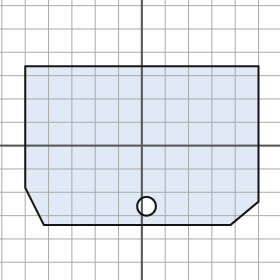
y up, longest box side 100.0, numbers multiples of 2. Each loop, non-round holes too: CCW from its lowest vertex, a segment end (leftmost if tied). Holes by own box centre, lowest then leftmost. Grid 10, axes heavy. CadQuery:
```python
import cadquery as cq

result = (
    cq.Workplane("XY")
    .moveTo(-42.0, -34.0)
    .lineTo(38.0, -34.0)
    .lineTo(50.0, -24.0)
    .lineTo(50.0, 34.0)
    .lineTo(-50.0, 34.0)
    .lineTo(-50.0, -18.0)
    .close()
    .moveTo(2.0, -26.0)
    .circle(4.0)
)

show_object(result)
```